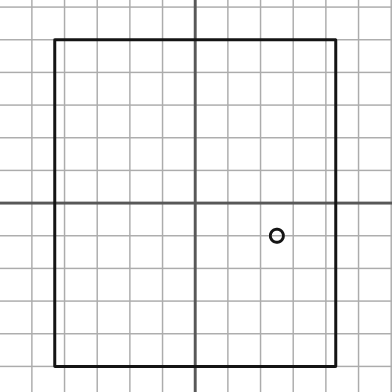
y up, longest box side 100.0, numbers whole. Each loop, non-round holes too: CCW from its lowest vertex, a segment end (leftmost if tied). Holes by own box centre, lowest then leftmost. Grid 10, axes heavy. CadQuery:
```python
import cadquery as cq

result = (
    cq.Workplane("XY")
    .moveTo(-43.0, -50.0)
    .lineTo(43.0, -50.0)
    .lineTo(43.0, 50.0)
    .lineTo(-43.0, 50.0)
    .close()
    .moveTo(25.0, -10.0)
    .circle(2.0)
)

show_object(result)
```